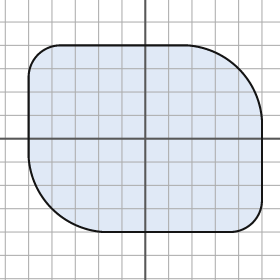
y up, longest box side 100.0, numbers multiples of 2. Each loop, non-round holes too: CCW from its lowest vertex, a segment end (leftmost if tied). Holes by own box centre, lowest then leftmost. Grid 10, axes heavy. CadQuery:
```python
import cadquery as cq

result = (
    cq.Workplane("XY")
    .moveTo(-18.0, -40.0)
    .lineTo(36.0, -40.0)
    .threePointArc((46.0, -36.0), (50.0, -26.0))
    .lineTo(50.0, 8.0)
    .threePointArc((40.0, 30.0), (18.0, 40.0))
    .lineTo(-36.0, 40.0)
    .threePointArc((-46.0, 36.0), (-50.0, 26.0))
    .lineTo(-50.0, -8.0)
    .threePointArc((-40.0, -30.0), (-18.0, -40.0))
    .close()
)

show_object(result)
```